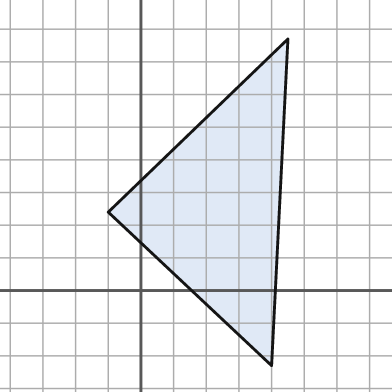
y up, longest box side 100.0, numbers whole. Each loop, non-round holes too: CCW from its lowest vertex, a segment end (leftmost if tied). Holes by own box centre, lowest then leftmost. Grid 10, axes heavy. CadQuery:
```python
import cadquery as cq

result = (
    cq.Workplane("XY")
    .moveTo(40.0, -23.0)
    .lineTo(45.0, 77.0)
    .lineTo(-10.0, 24.0)
    .close()
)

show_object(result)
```